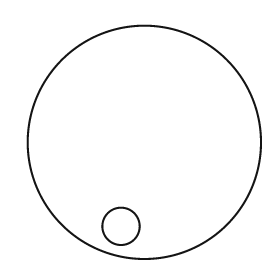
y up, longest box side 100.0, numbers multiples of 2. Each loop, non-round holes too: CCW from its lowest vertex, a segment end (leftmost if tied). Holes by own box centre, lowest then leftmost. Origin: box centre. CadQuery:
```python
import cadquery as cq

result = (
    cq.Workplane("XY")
    .moveTo(0.0, 0.0)
    .circle(50.0)
    .moveTo(-10.0, -36.0)
    .circle(8.0)
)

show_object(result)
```